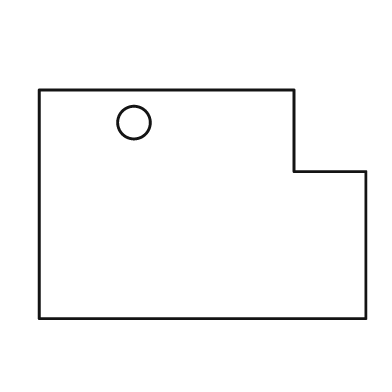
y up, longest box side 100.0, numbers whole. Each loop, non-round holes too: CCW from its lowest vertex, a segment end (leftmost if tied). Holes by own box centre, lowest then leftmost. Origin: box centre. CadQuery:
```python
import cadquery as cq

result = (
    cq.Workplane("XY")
    .moveTo(-50.0, -35.0)
    .lineTo(50.0, -35.0)
    .lineTo(50.0, 10.0)
    .lineTo(28.0, 10.0)
    .lineTo(28.0, 35.0)
    .lineTo(-50.0, 35.0)
    .close()
    .moveTo(-21.0, 25.0)
    .circle(5.0)
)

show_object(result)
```